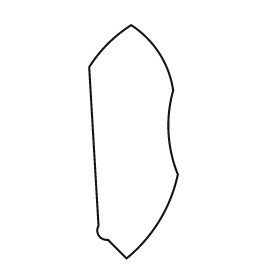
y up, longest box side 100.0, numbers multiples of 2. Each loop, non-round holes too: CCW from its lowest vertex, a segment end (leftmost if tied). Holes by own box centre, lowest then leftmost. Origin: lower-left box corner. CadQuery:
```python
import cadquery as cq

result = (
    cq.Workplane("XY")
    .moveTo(16.0, 0.0)
    .threePointArc((30.0, 16.0), (38.0, 36.0))
    .threePointArc((34.0, 54.0), (36.0, 72.0))
    .threePointArc((30.0, 88.0), (18.0, 100.0))
    .threePointArc((8.0, 92.0), (0.0, 82.0))
    .lineTo(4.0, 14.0)
    .threePointArc((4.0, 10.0), (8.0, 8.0))
    .close()
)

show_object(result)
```